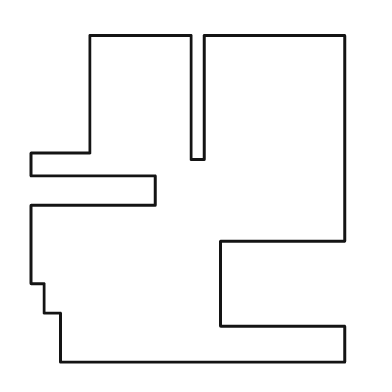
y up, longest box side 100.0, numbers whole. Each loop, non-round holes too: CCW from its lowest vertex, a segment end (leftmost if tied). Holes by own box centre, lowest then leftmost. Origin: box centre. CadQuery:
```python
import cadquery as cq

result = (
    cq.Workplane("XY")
    .moveTo(-39.0, -50.0)
    .lineTo(48.0, -50.0)
    .lineTo(48.0, -39.0)
    .lineTo(10.0, -39.0)
    .lineTo(10.0, -13.0)
    .lineTo(48.0, -13.0)
    .lineTo(48.0, 50.0)
    .lineTo(5.0, 50.0)
    .lineTo(5.0, 12.0)
    .lineTo(1.0, 12.0)
    .lineTo(1.0, 50.0)
    .lineTo(-30.0, 50.0)
    .lineTo(-30.0, 14.0)
    .lineTo(-48.0, 14.0)
    .lineTo(-48.0, 7.0)
    .lineTo(-10.0, 7.0)
    .lineTo(-10.0, -2.0)
    .lineTo(-48.0, -2.0)
    .lineTo(-48.0, -26.0)
    .lineTo(-44.0, -26.0)
    .lineTo(-44.0, -35.0)
    .lineTo(-39.0, -35.0)
    .close()
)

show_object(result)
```